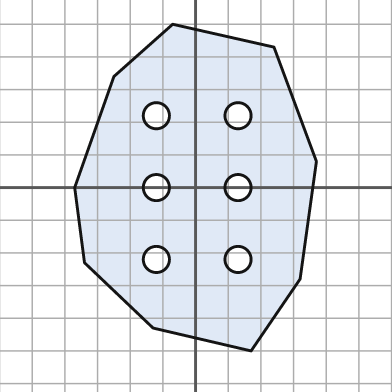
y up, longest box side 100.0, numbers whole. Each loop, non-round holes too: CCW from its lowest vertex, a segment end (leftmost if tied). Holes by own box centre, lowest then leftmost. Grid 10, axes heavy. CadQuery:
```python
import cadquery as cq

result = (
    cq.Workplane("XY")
    .moveTo(17.0, -50.0)
    .lineTo(32.0, -28.0)
    .lineTo(37.0, 8.0)
    .lineTo(24.0, 43.0)
    .lineTo(-7.0, 50.0)
    .lineTo(-25.0, 34.0)
    .lineTo(-37.0, 0.0)
    .lineTo(-34.0, -23.0)
    .lineTo(-13.0, -43.0)
    .close()
    .moveTo(-12.0, -22.0)
    .circle(4.0)
    .moveTo(13.0, -22.0)
    .circle(4.0)
    .moveTo(-12.0, 0.0)
    .circle(4.0)
    .moveTo(13.0, 0.0)
    .circle(4.0)
    .moveTo(-12.0, 22.0)
    .circle(4.0)
    .moveTo(13.0, 22.0)
    .circle(4.0)
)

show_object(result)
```